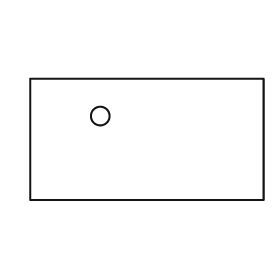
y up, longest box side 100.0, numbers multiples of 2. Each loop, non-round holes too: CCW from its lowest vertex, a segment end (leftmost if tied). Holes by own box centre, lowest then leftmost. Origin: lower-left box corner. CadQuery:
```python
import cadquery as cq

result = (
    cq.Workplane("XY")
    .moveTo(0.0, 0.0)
    .lineTo(100.0, 0.0)
    .lineTo(100.0, 52.0)
    .lineTo(0.0, 52.0)
    .close()
    .moveTo(30.0, 36.0)
    .circle(4.0)
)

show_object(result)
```